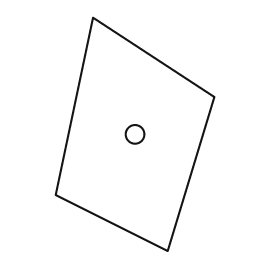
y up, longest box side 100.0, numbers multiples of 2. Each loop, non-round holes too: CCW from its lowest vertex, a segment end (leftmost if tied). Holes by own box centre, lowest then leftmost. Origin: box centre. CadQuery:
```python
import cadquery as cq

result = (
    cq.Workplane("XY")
    .moveTo(14.0, -50.0)
    .lineTo(34.0, 16.0)
    .lineTo(-18.0, 50.0)
    .lineTo(-34.0, -26.0)
    .close()
    .moveTo(0.0, 0.0)
    .circle(4.0)
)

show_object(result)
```